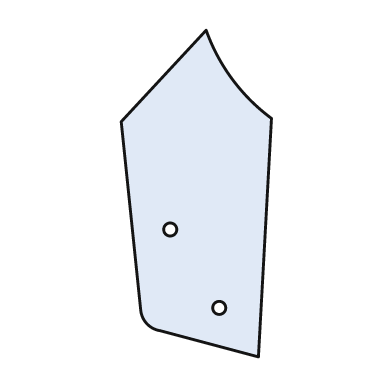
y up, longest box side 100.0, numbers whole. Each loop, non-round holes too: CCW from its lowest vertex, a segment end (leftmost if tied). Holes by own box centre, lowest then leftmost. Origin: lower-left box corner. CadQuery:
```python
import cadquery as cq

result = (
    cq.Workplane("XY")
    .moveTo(42.0, 0.0)
    .lineTo(46.0, 73.0)
    .threePointArc((34.0, 85.0), (26.0, 100.0))
    .lineTo(0.0, 72.0)
    .lineTo(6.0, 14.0)
    .threePointArc((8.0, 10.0), (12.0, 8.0))
    .close()
    .moveTo(30.0, 15.0)
    .circle(2.0)
    .moveTo(15.0, 39.0)
    .circle(2.0)
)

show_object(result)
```